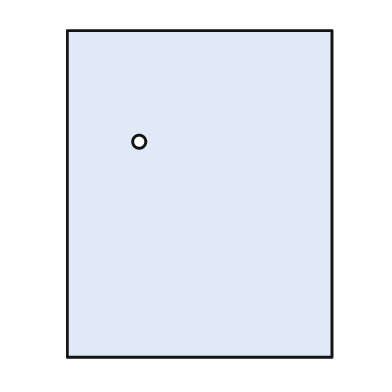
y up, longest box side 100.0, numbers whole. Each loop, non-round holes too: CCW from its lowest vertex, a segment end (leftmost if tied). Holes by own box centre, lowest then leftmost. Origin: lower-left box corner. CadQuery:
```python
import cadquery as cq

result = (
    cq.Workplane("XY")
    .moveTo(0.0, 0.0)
    .lineTo(81.0, 0.0)
    .lineTo(81.0, 100.0)
    .lineTo(0.0, 100.0)
    .close()
    .moveTo(22.0, 66.0)
    .circle(2.0)
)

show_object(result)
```